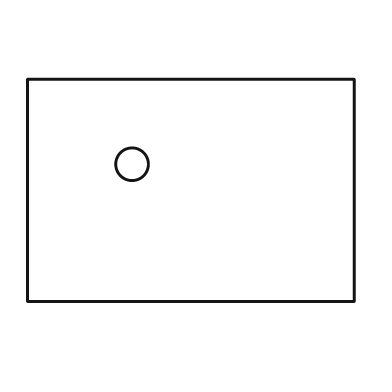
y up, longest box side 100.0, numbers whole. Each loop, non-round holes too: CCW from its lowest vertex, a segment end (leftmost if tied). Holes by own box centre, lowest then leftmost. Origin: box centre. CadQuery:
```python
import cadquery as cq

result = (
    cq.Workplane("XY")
    .moveTo(-50.0, -34.0)
    .lineTo(50.0, -34.0)
    .lineTo(50.0, 34.0)
    .lineTo(-50.0, 34.0)
    .close()
    .moveTo(-18.0, 8.0)
    .circle(5.0)
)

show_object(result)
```